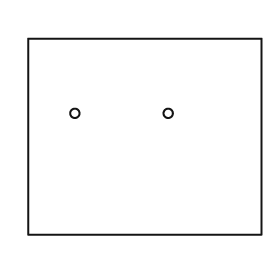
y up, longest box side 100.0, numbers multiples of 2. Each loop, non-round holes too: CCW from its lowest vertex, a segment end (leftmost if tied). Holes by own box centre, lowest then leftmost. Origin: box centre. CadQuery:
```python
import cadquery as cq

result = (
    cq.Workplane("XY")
    .moveTo(-50.0, -42.0)
    .lineTo(50.0, -42.0)
    .lineTo(50.0, 42.0)
    .lineTo(-50.0, 42.0)
    .close()
    .moveTo(-30.0, 10.0)
    .circle(2.0)
    .moveTo(10.0, 10.0)
    .circle(2.0)
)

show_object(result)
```